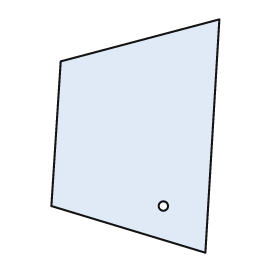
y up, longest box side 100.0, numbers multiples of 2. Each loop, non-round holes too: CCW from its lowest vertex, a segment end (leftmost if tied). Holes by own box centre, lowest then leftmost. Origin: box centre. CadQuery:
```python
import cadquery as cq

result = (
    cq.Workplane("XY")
    .moveTo(30.0, -50.0)
    .lineTo(36.0, 50.0)
    .lineTo(-32.0, 32.0)
    .lineTo(-36.0, -30.0)
    .close()
    .moveTo(12.0, -30.0)
    .circle(2.0)
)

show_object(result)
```